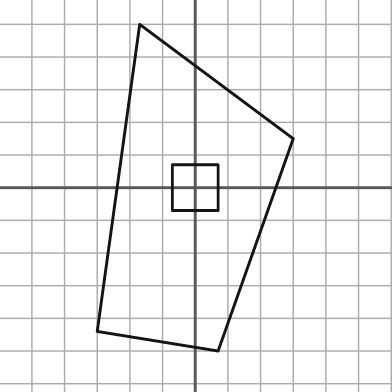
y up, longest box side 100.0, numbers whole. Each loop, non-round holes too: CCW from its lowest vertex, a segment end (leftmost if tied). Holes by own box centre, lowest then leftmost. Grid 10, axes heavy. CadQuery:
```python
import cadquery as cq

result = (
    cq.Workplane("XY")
    .moveTo(7.0, -50.0)
    .lineTo(30.0, 15.0)
    .lineTo(-17.0, 50.0)
    .lineTo(-30.0, -44.0)
    .close()
    .moveTo(-7.0, -7.0)
    .lineTo(7.0, -7.0)
    .lineTo(7.0, 7.0)
    .lineTo(-7.0, 7.0)
    .close()
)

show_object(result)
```